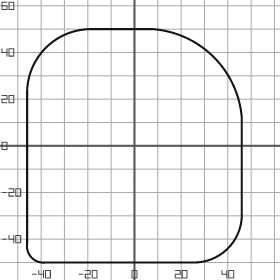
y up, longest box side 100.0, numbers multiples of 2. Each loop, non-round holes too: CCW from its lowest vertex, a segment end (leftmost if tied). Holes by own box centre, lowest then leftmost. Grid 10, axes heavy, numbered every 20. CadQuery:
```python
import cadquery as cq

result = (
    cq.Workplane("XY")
    .moveTo(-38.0, -50.0)
    .lineTo(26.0, -50.0)
    .threePointArc((40.0, -44.0), (46.0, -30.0))
    .lineTo(46.0, 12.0)
    .threePointArc((34.0, 38.0), (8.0, 50.0))
    .lineTo(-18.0, 50.0)
    .threePointArc((-38.0, 42.0), (-46.0, 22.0))
    .lineTo(-46.0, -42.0)
    .threePointArc((-44.0, -48.0), (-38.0, -50.0))
    .close()
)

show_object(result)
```